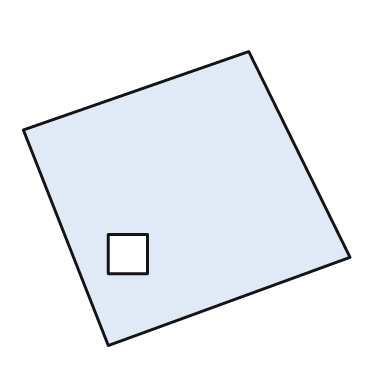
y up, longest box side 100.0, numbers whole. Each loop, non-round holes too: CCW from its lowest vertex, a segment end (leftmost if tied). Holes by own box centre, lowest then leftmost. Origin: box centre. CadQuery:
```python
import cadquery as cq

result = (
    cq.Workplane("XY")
    .moveTo(-24.0, -45.0)
    .lineTo(50.0, -18.0)
    .lineTo(19.0, 45.0)
    .lineTo(-50.0, 21.0)
    .close()
    .moveTo(-24.0, -23.0)
    .lineTo(-12.0, -23.0)
    .lineTo(-12.0, -11.0)
    .lineTo(-24.0, -11.0)
    .close()
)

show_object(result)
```